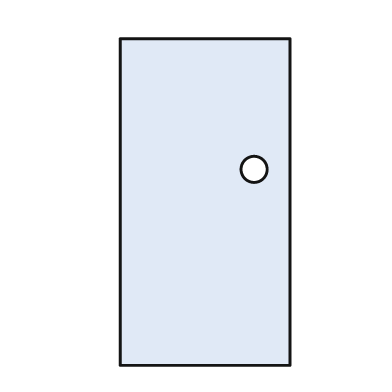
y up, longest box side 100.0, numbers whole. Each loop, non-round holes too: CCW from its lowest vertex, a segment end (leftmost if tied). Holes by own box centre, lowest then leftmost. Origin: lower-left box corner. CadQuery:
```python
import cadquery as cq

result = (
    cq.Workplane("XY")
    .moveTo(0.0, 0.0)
    .lineTo(52.0, 0.0)
    .lineTo(52.0, 100.0)
    .lineTo(0.0, 100.0)
    .close()
    .moveTo(41.0, 60.0)
    .circle(4.0)
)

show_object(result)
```